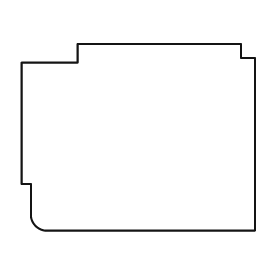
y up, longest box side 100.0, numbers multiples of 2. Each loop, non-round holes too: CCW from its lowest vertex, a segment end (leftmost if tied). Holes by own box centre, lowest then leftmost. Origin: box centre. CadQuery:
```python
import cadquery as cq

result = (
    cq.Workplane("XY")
    .moveTo(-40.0, -40.0)
    .lineTo(50.0, -40.0)
    .lineTo(50.0, 34.0)
    .lineTo(44.0, 34.0)
    .lineTo(44.0, 40.0)
    .lineTo(-26.0, 40.0)
    .lineTo(-26.0, 32.0)
    .lineTo(-50.0, 32.0)
    .lineTo(-50.0, -20.0)
    .lineTo(-46.0, -20.0)
    .lineTo(-46.0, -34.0)
    .threePointArc((-44.0, -38.0), (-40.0, -40.0))
    .close()
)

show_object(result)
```